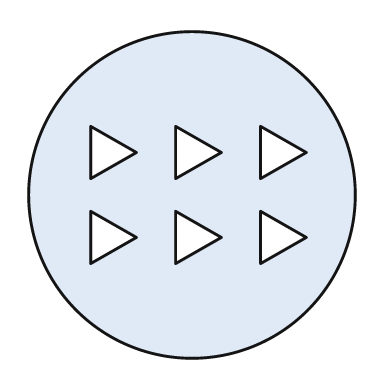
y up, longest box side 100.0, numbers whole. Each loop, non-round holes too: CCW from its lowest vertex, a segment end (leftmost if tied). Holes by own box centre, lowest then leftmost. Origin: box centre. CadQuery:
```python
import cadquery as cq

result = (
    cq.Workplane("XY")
    .moveTo(0.0, 0.0)
    .circle(50.0)
    .moveTo(-31.0, -21.0)
    .lineTo(-17.0, -13.0)
    .lineTo(-31.0, -5.0)
    .close()
    .moveTo(-5.0, -21.0)
    .lineTo(9.0, -13.0)
    .lineTo(-5.0, -5.0)
    .close()
    .moveTo(21.0, -21.0)
    .lineTo(35.0, -13.0)
    .lineTo(21.0, -5.0)
    .close()
    .moveTo(-31.0, 5.0)
    .lineTo(-17.0, 13.0)
    .lineTo(-31.0, 21.0)
    .close()
    .moveTo(-5.0, 5.0)
    .lineTo(9.0, 13.0)
    .lineTo(-5.0, 21.0)
    .close()
    .moveTo(21.0, 5.0)
    .lineTo(35.0, 13.0)
    .lineTo(21.0, 21.0)
    .close()
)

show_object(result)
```